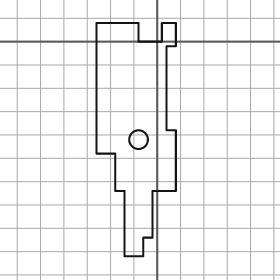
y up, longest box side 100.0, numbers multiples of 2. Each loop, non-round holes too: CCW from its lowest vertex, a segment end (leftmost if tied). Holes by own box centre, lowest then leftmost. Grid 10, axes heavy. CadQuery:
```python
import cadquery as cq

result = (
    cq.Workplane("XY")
    .moveTo(-14.0, -92.0)
    .lineTo(-6.0, -92.0)
    .lineTo(-6.0, -84.0)
    .lineTo(-2.0, -84.0)
    .lineTo(-2.0, -64.0)
    .lineTo(8.0, -64.0)
    .lineTo(8.0, -38.0)
    .lineTo(4.0, -38.0)
    .lineTo(4.0, -2.0)
    .lineTo(8.0, -2.0)
    .lineTo(8.0, 8.0)
    .lineTo(2.0, 8.0)
    .lineTo(2.0, 0.0)
    .lineTo(-8.0, 0.0)
    .lineTo(-8.0, 8.0)
    .lineTo(-26.0, 8.0)
    .lineTo(-26.0, -48.0)
    .lineTo(-18.0, -48.0)
    .lineTo(-18.0, -64.0)
    .lineTo(-14.0, -64.0)
    .close()
    .moveTo(-8.0, -42.0)
    .circle(4.0)
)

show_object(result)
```